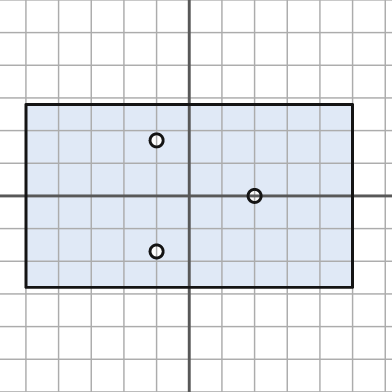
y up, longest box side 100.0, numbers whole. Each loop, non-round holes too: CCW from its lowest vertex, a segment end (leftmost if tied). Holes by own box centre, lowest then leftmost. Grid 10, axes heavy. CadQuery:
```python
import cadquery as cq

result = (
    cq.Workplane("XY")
    .moveTo(-50.0, -28.0)
    .lineTo(50.0, -28.0)
    .lineTo(50.0, 28.0)
    .lineTo(-50.0, 28.0)
    .close()
    .moveTo(-10.0, -17.0)
    .circle(2.0)
    .moveTo(20.0, 0.0)
    .circle(2.0)
    .moveTo(-10.0, 17.0)
    .circle(2.0)
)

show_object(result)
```